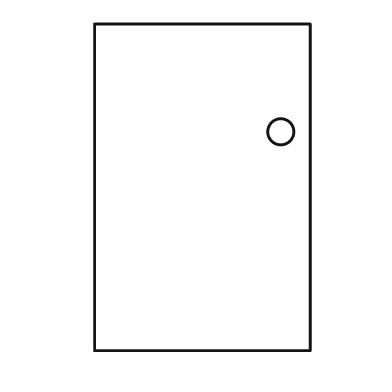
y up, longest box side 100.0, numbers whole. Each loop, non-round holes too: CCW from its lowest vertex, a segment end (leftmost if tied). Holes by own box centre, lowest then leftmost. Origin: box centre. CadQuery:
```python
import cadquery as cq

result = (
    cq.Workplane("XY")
    .moveTo(-33.0, -50.0)
    .lineTo(33.0, -50.0)
    .lineTo(33.0, 50.0)
    .lineTo(-33.0, 50.0)
    .close()
    .moveTo(24.0, 17.0)
    .circle(4.0)
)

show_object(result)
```